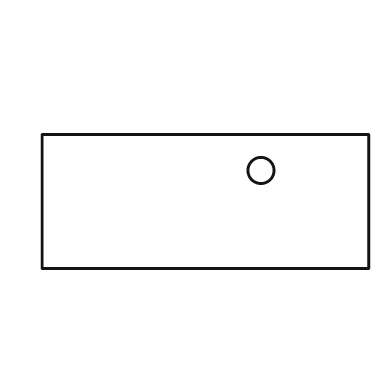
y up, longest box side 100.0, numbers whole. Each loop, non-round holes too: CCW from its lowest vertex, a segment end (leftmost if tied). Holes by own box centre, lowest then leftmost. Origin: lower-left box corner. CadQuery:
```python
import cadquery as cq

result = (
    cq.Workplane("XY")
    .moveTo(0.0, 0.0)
    .lineTo(100.0, 0.0)
    .lineTo(100.0, 41.0)
    .lineTo(0.0, 41.0)
    .close()
    .moveTo(67.0, 30.0)
    .circle(4.0)
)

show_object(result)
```